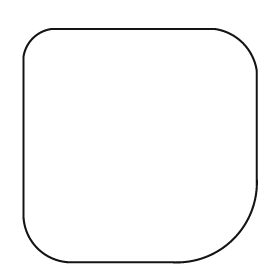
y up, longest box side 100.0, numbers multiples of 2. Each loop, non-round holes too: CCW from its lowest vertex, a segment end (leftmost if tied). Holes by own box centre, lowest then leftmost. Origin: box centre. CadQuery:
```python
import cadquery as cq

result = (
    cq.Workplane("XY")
    .moveTo(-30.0, -50.0)
    .lineTo(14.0, -50.0)
    .threePointArc((40.0, -40.0), (50.0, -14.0))
    .lineTo(50.0, 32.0)
    .threePointArc((44.0, 44.0), (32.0, 50.0))
    .lineTo(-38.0, 50.0)
    .threePointArc((-46.0, 46.0), (-50.0, 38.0))
    .lineTo(-50.0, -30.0)
    .threePointArc((-44.0, -44.0), (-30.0, -50.0))
    .close()
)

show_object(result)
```